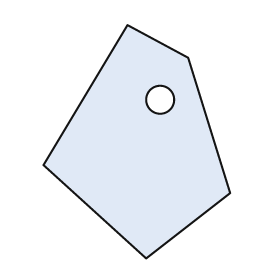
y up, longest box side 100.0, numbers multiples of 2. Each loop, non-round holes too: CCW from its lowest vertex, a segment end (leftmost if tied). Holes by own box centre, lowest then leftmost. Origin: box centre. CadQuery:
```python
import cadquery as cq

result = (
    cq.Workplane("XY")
    .moveTo(4.0, -50.0)
    .lineTo(40.0, -22.0)
    .lineTo(22.0, 36.0)
    .lineTo(-4.0, 50.0)
    .lineTo(-40.0, -10.0)
    .close()
    .moveTo(10.0, 18.0)
    .circle(6.0)
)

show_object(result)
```